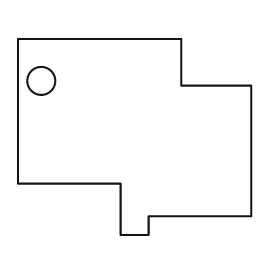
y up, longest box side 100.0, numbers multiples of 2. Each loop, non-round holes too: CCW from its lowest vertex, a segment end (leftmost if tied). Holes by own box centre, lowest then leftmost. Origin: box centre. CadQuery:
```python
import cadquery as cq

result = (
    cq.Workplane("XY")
    .moveTo(-6.0, -42.0)
    .lineTo(6.0, -42.0)
    .lineTo(6.0, -34.0)
    .lineTo(50.0, -34.0)
    .lineTo(50.0, 22.0)
    .lineTo(20.0, 22.0)
    .lineTo(20.0, 42.0)
    .lineTo(-50.0, 42.0)
    .lineTo(-50.0, -20.0)
    .lineTo(-6.0, -20.0)
    .close()
    .moveTo(-40.0, 24.0)
    .circle(6.0)
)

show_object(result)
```